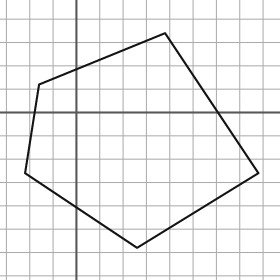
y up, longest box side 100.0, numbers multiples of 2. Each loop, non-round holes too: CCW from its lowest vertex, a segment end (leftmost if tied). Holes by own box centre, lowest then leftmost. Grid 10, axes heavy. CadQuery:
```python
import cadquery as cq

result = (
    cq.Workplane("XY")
    .moveTo(26.0, -58.0)
    .lineTo(78.0, -26.0)
    .lineTo(38.0, 34.0)
    .lineTo(-16.0, 12.0)
    .lineTo(-22.0, -26.0)
    .close()
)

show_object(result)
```